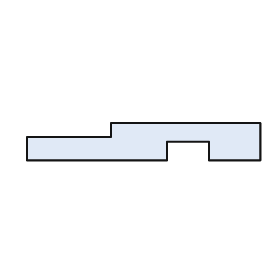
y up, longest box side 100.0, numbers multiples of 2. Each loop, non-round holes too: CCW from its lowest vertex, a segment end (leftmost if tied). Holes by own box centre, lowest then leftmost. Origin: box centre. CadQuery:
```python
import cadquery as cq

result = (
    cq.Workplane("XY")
    .moveTo(-50.0, -8.0)
    .lineTo(10.0, -8.0)
    .lineTo(10.0, 0.0)
    .lineTo(28.0, 0.0)
    .lineTo(28.0, -8.0)
    .lineTo(50.0, -8.0)
    .lineTo(50.0, 8.0)
    .lineTo(-14.0, 8.0)
    .lineTo(-14.0, 2.0)
    .lineTo(-50.0, 2.0)
    .close()
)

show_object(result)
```